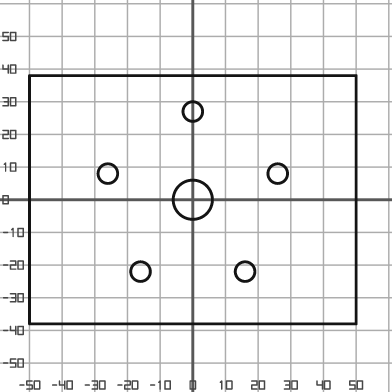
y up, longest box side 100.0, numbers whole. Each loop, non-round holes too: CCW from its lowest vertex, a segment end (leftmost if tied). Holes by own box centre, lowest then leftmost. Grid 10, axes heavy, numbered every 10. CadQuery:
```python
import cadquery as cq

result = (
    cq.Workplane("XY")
    .moveTo(-50.0, -38.0)
    .lineTo(50.0, -38.0)
    .lineTo(50.0, 38.0)
    .lineTo(-50.0, 38.0)
    .close()
    .moveTo(-16.0, -22.0)
    .circle(3.0)
    .moveTo(16.0, -22.0)
    .circle(3.0)
    .moveTo(0.0, 0.0)
    .circle(6.0)
    .moveTo(-26.0, 8.0)
    .circle(3.0)
    .moveTo(26.0, 8.0)
    .circle(3.0)
    .moveTo(0.0, 27.0)
    .circle(3.0)
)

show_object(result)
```